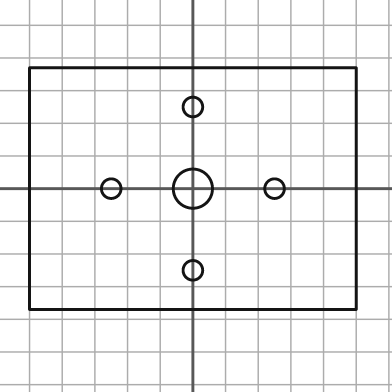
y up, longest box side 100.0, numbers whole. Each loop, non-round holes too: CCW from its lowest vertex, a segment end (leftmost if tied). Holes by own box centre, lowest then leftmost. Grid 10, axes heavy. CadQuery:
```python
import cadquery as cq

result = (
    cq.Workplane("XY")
    .moveTo(-50.0, -37.0)
    .lineTo(50.0, -37.0)
    .lineTo(50.0, 37.0)
    .lineTo(-50.0, 37.0)
    .close()
    .moveTo(0.0, -25.0)
    .circle(3.0)
    .moveTo(-25.0, 0.0)
    .circle(3.0)
    .moveTo(0.0, 0.0)
    .circle(6.0)
    .moveTo(25.0, 0.0)
    .circle(3.0)
    .moveTo(0.0, 25.0)
    .circle(3.0)
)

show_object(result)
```